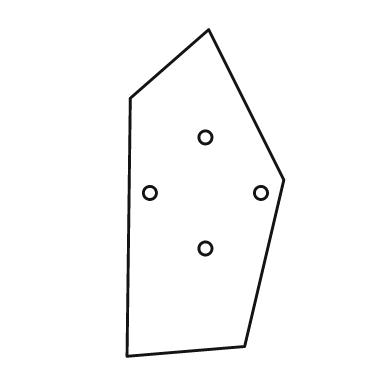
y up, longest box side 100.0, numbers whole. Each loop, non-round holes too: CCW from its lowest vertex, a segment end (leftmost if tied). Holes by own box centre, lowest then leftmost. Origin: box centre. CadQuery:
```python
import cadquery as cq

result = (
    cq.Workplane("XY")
    .moveTo(-24.0, -50.0)
    .lineTo(12.0, -47.0)
    .lineTo(24.0, 4.0)
    .lineTo(1.0, 50.0)
    .lineTo(-23.0, 29.0)
    .close()
    .moveTo(0.0, -17.0)
    .circle(2.0)
    .moveTo(-17.0, 0.0)
    .circle(2.0)
    .moveTo(17.0, 0.0)
    .circle(2.0)
    .moveTo(0.0, 17.0)
    .circle(2.0)
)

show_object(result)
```